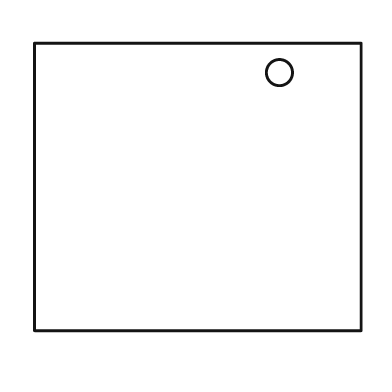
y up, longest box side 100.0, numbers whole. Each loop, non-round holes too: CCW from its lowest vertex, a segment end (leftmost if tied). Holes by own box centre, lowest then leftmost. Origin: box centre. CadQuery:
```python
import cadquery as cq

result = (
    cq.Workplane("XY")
    .moveTo(-50.0, -44.0)
    .lineTo(50.0, -44.0)
    .lineTo(50.0, 44.0)
    .lineTo(-50.0, 44.0)
    .close()
    .moveTo(25.0, 35.0)
    .circle(4.0)
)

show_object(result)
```